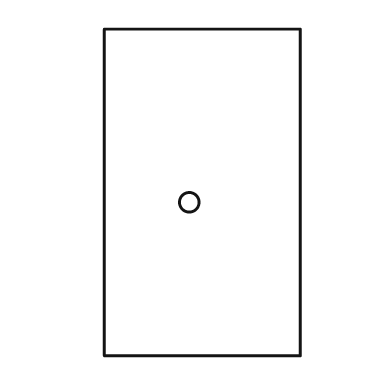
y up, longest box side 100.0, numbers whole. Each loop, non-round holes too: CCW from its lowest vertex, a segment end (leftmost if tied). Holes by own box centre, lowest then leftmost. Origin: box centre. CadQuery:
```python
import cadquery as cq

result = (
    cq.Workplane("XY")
    .moveTo(-30.0, -50.0)
    .lineTo(30.0, -50.0)
    .lineTo(30.0, 50.0)
    .lineTo(-30.0, 50.0)
    .close()
    .moveTo(-4.0, -3.0)
    .circle(3.0)
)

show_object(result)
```